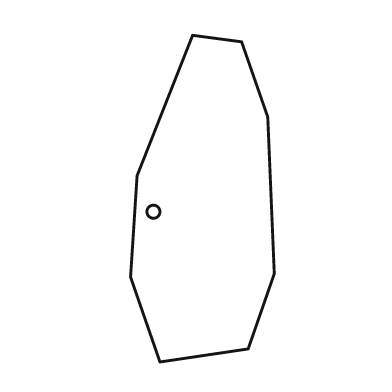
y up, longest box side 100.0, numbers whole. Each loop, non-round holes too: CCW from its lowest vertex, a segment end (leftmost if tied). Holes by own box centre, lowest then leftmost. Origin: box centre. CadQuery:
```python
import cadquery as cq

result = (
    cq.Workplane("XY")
    .moveTo(-13.0, -50.0)
    .lineTo(14.0, -46.0)
    .lineTo(22.0, -23.0)
    .lineTo(20.0, 25.0)
    .lineTo(12.0, 48.0)
    .lineTo(-3.0, 50.0)
    .lineTo(-20.0, 7.0)
    .lineTo(-22.0, -24.0)
    .close()
    .moveTo(-15.0, -4.0)
    .circle(2.0)
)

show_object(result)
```